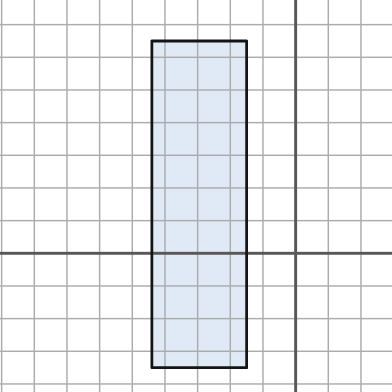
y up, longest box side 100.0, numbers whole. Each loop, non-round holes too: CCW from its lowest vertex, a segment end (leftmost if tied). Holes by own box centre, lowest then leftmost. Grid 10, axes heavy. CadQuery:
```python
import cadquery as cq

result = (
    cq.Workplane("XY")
    .moveTo(-44.0, -35.0)
    .lineTo(-15.0, -35.0)
    .lineTo(-15.0, 65.0)
    .lineTo(-44.0, 65.0)
    .close()
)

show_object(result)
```